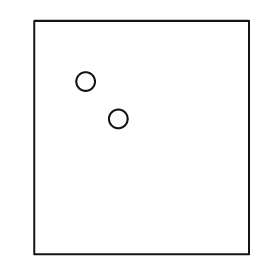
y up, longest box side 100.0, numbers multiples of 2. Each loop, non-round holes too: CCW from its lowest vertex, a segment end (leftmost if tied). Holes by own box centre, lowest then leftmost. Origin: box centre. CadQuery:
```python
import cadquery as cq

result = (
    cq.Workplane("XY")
    .moveTo(-46.0, -50.0)
    .lineTo(46.0, -50.0)
    .lineTo(46.0, 50.0)
    .lineTo(-46.0, 50.0)
    .close()
    .moveTo(-10.0, 8.0)
    .circle(4.0)
    .moveTo(-24.0, 24.0)
    .circle(4.0)
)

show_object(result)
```